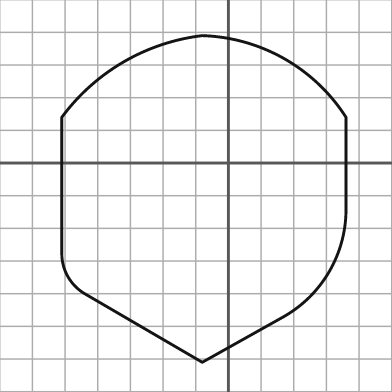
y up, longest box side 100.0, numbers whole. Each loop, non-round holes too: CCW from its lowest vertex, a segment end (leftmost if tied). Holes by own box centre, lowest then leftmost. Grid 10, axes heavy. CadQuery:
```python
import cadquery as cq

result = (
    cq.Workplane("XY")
    .moveTo(-8.0, -61.0)
    .lineTo(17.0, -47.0)
    .threePointArc((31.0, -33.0), (36.0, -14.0))
    .lineTo(36.0, 14.0)
    .threePointArc((17.0, 32.0), (-8.0, 39.0))
    .threePointArc((-32.0, 31.0), (-51.0, 14.0))
    .lineTo(-51.0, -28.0)
    .threePointArc((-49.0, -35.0), (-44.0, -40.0))
    .close()
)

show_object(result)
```